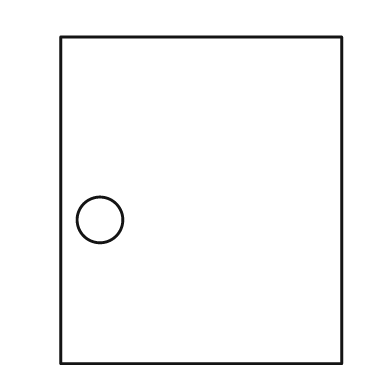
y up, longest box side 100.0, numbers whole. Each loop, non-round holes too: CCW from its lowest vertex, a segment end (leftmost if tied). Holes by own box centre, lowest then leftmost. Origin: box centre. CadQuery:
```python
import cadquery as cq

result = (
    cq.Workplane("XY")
    .moveTo(-43.0, -50.0)
    .lineTo(43.0, -50.0)
    .lineTo(43.0, 50.0)
    .lineTo(-43.0, 50.0)
    .close()
    .moveTo(-31.0, -6.0)
    .circle(7.0)
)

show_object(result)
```